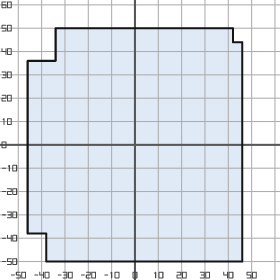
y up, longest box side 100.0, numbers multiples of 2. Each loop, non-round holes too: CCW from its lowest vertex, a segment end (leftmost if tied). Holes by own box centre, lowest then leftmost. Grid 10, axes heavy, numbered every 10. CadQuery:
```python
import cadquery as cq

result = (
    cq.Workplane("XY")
    .moveTo(-38.0, -50.0)
    .lineTo(46.0, -50.0)
    .lineTo(46.0, 44.0)
    .lineTo(42.0, 44.0)
    .lineTo(42.0, 50.0)
    .lineTo(-34.0, 50.0)
    .lineTo(-34.0, 36.0)
    .lineTo(-46.0, 36.0)
    .lineTo(-46.0, -38.0)
    .lineTo(-38.0, -38.0)
    .close()
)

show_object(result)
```